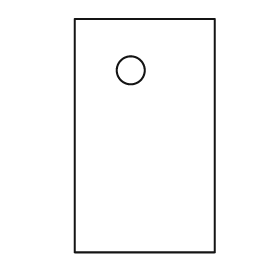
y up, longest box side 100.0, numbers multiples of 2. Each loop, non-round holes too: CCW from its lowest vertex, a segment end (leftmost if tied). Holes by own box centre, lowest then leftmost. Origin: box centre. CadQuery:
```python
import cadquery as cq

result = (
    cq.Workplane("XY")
    .moveTo(-30.0, -50.0)
    .lineTo(30.0, -50.0)
    .lineTo(30.0, 50.0)
    .lineTo(-30.0, 50.0)
    .close()
    .moveTo(-6.0, 28.0)
    .circle(6.0)
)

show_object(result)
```